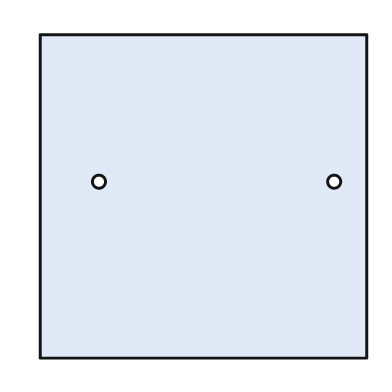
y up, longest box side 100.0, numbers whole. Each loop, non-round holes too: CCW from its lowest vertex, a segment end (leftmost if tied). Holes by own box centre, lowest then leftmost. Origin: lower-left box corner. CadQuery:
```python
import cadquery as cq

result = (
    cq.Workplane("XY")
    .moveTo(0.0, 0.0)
    .lineTo(100.0, 0.0)
    .lineTo(100.0, 99.0)
    .lineTo(0.0, 99.0)
    .close()
    .moveTo(18.0, 54.0)
    .circle(2.0)
    .moveTo(90.0, 54.0)
    .circle(2.0)
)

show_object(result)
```